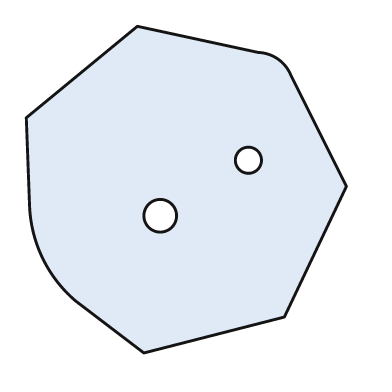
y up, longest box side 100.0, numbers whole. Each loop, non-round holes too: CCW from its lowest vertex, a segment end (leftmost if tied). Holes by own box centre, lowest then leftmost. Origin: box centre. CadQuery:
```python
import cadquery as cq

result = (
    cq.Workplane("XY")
    .moveTo(-13.0, -50.0)
    .lineTo(30.0, -39.0)
    .lineTo(49.0, 1.0)
    .lineTo(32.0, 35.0)
    .threePointArc((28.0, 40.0), (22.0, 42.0))
    .lineTo(-15.0, 50.0)
    .lineTo(-49.0, 22.0)
    .lineTo(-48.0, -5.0)
    .threePointArc((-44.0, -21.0), (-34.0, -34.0))
    .close()
    .moveTo(-8.0, -8.0)
    .circle(5.0)
    .moveTo(19.0, 9.0)
    .circle(4.0)
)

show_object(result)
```